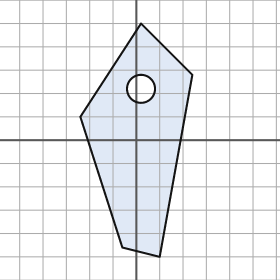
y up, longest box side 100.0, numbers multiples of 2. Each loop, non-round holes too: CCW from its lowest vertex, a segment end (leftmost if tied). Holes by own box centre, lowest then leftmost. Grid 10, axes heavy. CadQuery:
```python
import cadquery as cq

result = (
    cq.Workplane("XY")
    .moveTo(10.0, -50.0)
    .lineTo(24.0, 28.0)
    .lineTo(2.0, 50.0)
    .lineTo(-24.0, 10.0)
    .lineTo(-6.0, -46.0)
    .close()
    .moveTo(2.0, 22.0)
    .circle(6.0)
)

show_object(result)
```